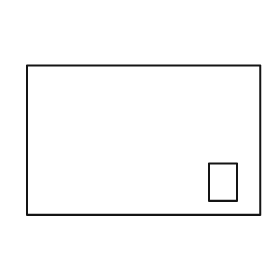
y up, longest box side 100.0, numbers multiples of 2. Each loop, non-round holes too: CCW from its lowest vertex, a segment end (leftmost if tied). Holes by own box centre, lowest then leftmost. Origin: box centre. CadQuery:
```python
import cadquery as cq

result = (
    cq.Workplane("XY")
    .moveTo(-50.0, -32.0)
    .lineTo(50.0, -32.0)
    .lineTo(50.0, 32.0)
    .lineTo(-50.0, 32.0)
    .close()
    .moveTo(28.0, -26.0)
    .lineTo(40.0, -26.0)
    .lineTo(40.0, -10.0)
    .lineTo(28.0, -10.0)
    .close()
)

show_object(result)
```